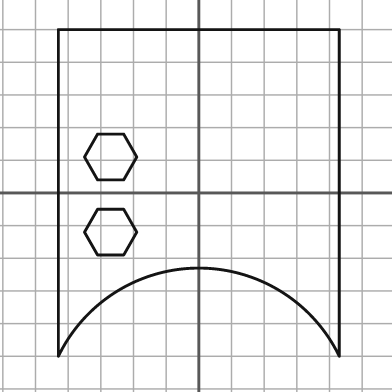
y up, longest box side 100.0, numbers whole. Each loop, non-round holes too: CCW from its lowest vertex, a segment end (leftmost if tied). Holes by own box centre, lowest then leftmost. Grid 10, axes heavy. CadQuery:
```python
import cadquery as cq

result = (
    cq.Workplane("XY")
    .moveTo(-43.0, -50.0)
    .threePointArc((0.0, -23.0), (43.0, -50.0))
    .lineTo(43.0, 50.0)
    .lineTo(-43.0, 50.0)
    .close()
    .moveTo(-31.0, -19.0)
    .lineTo(-23.0, -19.0)
    .lineTo(-19.0, -12.0)
    .lineTo(-23.0, -5.0)
    .lineTo(-31.0, -5.0)
    .lineTo(-35.0, -12.0)
    .close()
    .moveTo(-31.0, 4.0)
    .lineTo(-23.0, 4.0)
    .lineTo(-19.0, 11.0)
    .lineTo(-23.0, 18.0)
    .lineTo(-31.0, 18.0)
    .lineTo(-35.0, 11.0)
    .close()
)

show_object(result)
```